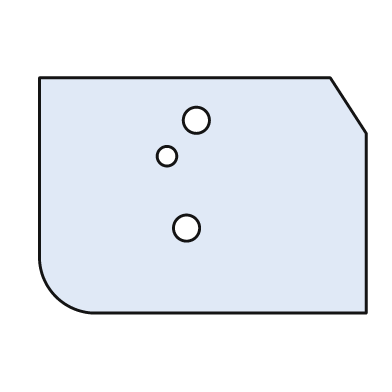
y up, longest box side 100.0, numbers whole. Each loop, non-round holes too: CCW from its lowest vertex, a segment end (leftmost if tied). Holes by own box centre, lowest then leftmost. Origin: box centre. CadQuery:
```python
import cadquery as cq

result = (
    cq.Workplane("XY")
    .moveTo(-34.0, -36.0)
    .lineTo(50.0, -36.0)
    .lineTo(50.0, 19.0)
    .lineTo(39.0, 36.0)
    .lineTo(-50.0, 36.0)
    .lineTo(-50.0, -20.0)
    .threePointArc((-45.0, -31.0), (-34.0, -36.0))
    .close()
    .moveTo(-5.0, -10.0)
    .circle(4.0)
    .moveTo(-11.0, 12.0)
    .circle(3.0)
    .moveTo(-2.0, 23.0)
    .circle(4.0)
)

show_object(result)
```